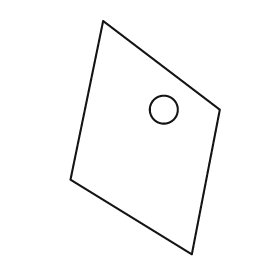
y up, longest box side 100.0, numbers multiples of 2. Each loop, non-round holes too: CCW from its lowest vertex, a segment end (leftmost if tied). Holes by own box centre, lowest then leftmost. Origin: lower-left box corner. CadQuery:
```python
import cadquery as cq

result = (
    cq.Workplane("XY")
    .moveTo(52.0, 0.0)
    .lineTo(64.0, 62.0)
    .lineTo(14.0, 100.0)
    .lineTo(0.0, 32.0)
    .close()
    .moveTo(40.0, 62.0)
    .circle(6.0)
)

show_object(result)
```